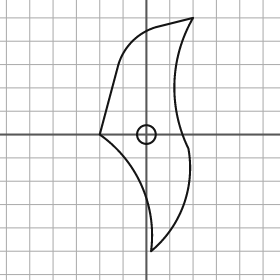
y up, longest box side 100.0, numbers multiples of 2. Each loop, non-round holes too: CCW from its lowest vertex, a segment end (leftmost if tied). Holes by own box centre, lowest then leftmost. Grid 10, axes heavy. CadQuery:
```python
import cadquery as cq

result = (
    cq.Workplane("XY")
    .moveTo(2.0, -50.0)
    .threePointArc((16.0, -30.0), (18.0, -6.0))
    .threePointArc((12.0, 22.0), (20.0, 50.0))
    .lineTo(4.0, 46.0)
    .threePointArc((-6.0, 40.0), (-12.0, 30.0))
    .lineTo(-20.0, 0.0)
    .threePointArc((-2.0, -22.0), (2.0, -50.0))
    .close()
    .moveTo(0.0, 0.0)
    .circle(4.0)
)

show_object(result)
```